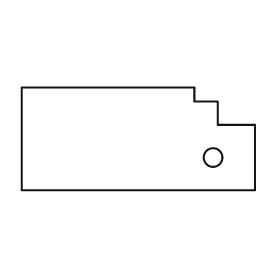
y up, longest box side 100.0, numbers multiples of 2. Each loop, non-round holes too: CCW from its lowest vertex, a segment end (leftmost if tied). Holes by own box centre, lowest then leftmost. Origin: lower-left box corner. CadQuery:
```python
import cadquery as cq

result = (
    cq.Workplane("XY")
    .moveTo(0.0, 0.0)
    .lineTo(100.0, 0.0)
    .lineTo(100.0, 28.0)
    .lineTo(84.0, 28.0)
    .lineTo(84.0, 38.0)
    .lineTo(74.0, 38.0)
    .lineTo(74.0, 44.0)
    .lineTo(0.0, 44.0)
    .close()
    .moveTo(82.0, 14.0)
    .circle(4.0)
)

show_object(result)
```